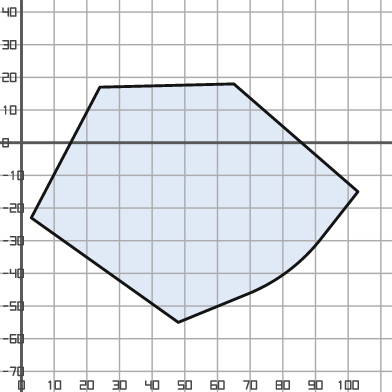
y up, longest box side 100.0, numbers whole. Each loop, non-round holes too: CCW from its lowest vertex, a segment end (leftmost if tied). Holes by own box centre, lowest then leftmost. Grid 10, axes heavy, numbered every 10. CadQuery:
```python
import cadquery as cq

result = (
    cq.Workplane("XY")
    .moveTo(48.0, -55.0)
    .lineTo(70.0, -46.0)
    .threePointArc((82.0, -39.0), (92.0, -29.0))
    .lineTo(103.0, -15.0)
    .lineTo(65.0, 18.0)
    .lineTo(24.0, 17.0)
    .lineTo(3.0, -23.0)
    .close()
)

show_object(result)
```